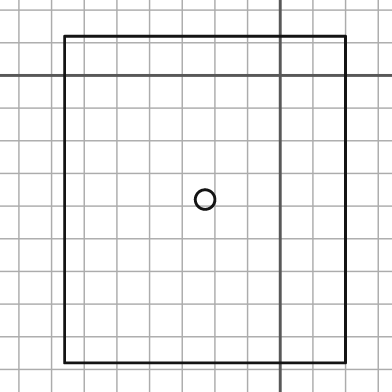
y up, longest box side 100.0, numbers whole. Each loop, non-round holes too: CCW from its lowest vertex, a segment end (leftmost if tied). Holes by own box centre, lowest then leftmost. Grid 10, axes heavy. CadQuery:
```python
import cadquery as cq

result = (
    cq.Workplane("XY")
    .moveTo(-66.0, -88.0)
    .lineTo(20.0, -88.0)
    .lineTo(20.0, 12.0)
    .lineTo(-66.0, 12.0)
    .close()
    .moveTo(-23.0, -38.0)
    .circle(3.0)
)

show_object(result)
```